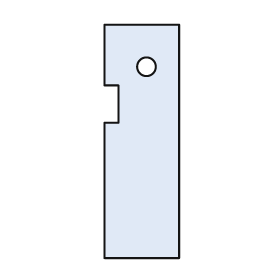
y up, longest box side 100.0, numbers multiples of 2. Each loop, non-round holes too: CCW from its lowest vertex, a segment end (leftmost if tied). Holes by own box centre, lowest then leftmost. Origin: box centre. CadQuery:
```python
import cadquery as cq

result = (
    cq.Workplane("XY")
    .moveTo(-16.0, -50.0)
    .lineTo(16.0, -50.0)
    .lineTo(16.0, 50.0)
    .lineTo(-16.0, 50.0)
    .lineTo(-16.0, 24.0)
    .lineTo(-10.0, 24.0)
    .lineTo(-10.0, 8.0)
    .lineTo(-16.0, 8.0)
    .close()
    .moveTo(2.0, 32.0)
    .circle(4.0)
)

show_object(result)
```